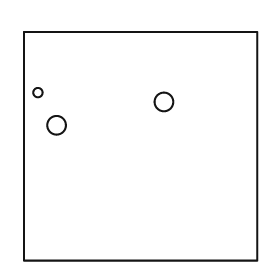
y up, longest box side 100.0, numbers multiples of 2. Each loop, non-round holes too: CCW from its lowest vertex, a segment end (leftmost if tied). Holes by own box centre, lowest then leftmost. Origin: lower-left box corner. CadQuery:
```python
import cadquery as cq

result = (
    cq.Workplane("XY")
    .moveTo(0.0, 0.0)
    .lineTo(100.0, 0.0)
    .lineTo(100.0, 98.0)
    .lineTo(0.0, 98.0)
    .close()
    .moveTo(14.0, 58.0)
    .circle(4.0)
    .moveTo(60.0, 68.0)
    .circle(4.0)
    .moveTo(6.0, 72.0)
    .circle(2.0)
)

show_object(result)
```